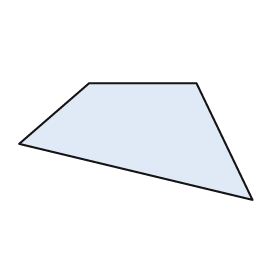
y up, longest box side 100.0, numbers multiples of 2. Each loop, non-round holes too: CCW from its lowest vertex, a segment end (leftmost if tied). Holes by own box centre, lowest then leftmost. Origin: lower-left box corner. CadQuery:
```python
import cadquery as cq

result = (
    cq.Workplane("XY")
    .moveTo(100.0, 0.0)
    .lineTo(76.0, 50.0)
    .lineTo(30.0, 50.0)
    .lineTo(0.0, 24.0)
    .close()
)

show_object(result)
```